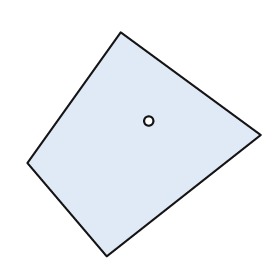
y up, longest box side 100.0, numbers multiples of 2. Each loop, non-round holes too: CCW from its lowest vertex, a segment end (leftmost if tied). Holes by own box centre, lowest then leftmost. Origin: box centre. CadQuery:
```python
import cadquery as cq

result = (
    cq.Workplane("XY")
    .moveTo(-16.0, -48.0)
    .lineTo(50.0, 4.0)
    .lineTo(-10.0, 48.0)
    .lineTo(-50.0, -8.0)
    .close()
    .moveTo(2.0, 10.0)
    .circle(2.0)
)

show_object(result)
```